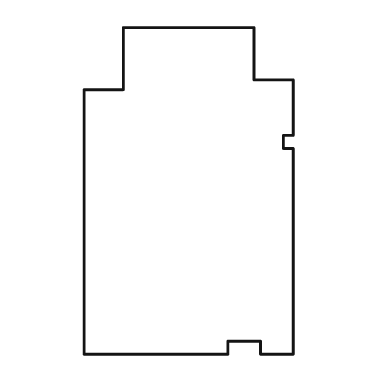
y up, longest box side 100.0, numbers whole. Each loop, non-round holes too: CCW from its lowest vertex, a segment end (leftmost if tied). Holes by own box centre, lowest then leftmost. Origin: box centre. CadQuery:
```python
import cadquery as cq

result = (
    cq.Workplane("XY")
    .moveTo(-32.0, -50.0)
    .lineTo(12.0, -50.0)
    .lineTo(12.0, -46.0)
    .lineTo(22.0, -46.0)
    .lineTo(22.0, -50.0)
    .lineTo(32.0, -50.0)
    .lineTo(32.0, 13.0)
    .lineTo(29.0, 13.0)
    .lineTo(29.0, 17.0)
    .lineTo(32.0, 17.0)
    .lineTo(32.0, 34.0)
    .lineTo(20.0, 34.0)
    .lineTo(20.0, 50.0)
    .lineTo(-20.0, 50.0)
    .lineTo(-20.0, 31.0)
    .lineTo(-32.0, 31.0)
    .close()
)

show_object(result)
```